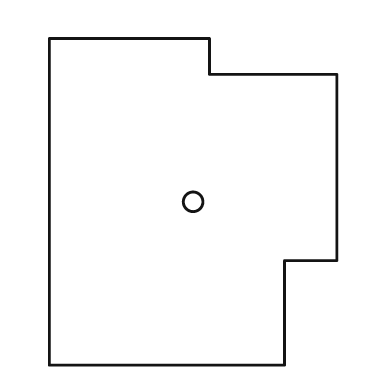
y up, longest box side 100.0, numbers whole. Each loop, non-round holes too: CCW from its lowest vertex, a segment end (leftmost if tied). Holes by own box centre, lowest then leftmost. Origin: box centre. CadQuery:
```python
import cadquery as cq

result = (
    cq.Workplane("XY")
    .moveTo(-44.0, -50.0)
    .lineTo(28.0, -50.0)
    .lineTo(28.0, -18.0)
    .lineTo(44.0, -18.0)
    .lineTo(44.0, 39.0)
    .lineTo(5.0, 39.0)
    .lineTo(5.0, 50.0)
    .lineTo(-44.0, 50.0)
    .close()
    .moveTo(0.0, 0.0)
    .circle(3.0)
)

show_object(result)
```